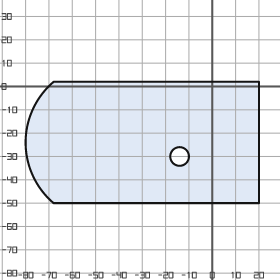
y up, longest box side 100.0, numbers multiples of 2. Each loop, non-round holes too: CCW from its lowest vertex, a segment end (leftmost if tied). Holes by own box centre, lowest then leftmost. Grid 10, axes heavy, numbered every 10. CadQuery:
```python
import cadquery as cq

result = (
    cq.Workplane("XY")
    .moveTo(-68.0, -50.0)
    .lineTo(20.0, -50.0)
    .lineTo(20.0, 2.0)
    .lineTo(-68.0, 2.0)
    .threePointArc((-80.0, -24.0), (-68.0, -50.0))
    .close()
    .moveTo(-14.0, -30.0)
    .circle(4.0)
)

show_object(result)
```